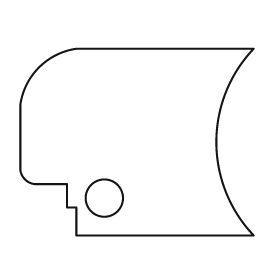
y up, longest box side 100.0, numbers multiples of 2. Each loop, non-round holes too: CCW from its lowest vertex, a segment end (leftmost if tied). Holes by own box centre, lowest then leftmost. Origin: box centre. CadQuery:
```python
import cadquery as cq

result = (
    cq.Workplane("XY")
    .moveTo(-26.0, -40.0)
    .lineTo(50.0, -40.0)
    .threePointArc((34.0, 0.0), (50.0, 40.0))
    .lineTo(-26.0, 40.0)
    .threePointArc((-42.0, 32.0), (-50.0, 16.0))
    .lineTo(-50.0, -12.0)
    .threePointArc((-48.0, -16.0), (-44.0, -18.0))
    .lineTo(-30.0, -18.0)
    .lineTo(-30.0, -28.0)
    .lineTo(-26.0, -28.0)
    .close()
    .moveTo(-14.0, -24.0)
    .circle(8.0)
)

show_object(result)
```